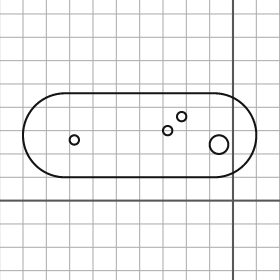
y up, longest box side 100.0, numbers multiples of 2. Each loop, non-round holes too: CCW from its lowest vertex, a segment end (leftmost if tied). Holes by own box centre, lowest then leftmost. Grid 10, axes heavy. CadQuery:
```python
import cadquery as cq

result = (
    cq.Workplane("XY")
    .moveTo(-72.0, 10.0)
    .lineTo(-8.0, 10.0)
    .threePointArc((10.0, 28.0), (-8.0, 46.0))
    .lineTo(-72.0, 46.0)
    .threePointArc((-90.0, 28.0), (-72.0, 10.0))
    .close()
    .moveTo(-6.0, 24.0)
    .circle(4.0)
    .moveTo(-68.0, 26.0)
    .circle(2.0)
    .moveTo(-28.0, 30.0)
    .circle(2.0)
    .moveTo(-22.0, 36.0)
    .circle(2.0)
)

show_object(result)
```